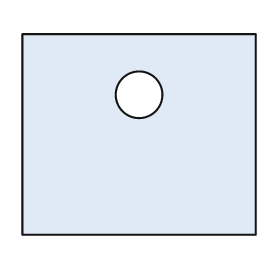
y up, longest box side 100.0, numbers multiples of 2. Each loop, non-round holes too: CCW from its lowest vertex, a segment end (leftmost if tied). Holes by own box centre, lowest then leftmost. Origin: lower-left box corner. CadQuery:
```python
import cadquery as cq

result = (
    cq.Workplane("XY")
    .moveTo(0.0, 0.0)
    .lineTo(100.0, 0.0)
    .lineTo(100.0, 86.0)
    .lineTo(0.0, 86.0)
    .close()
    .moveTo(50.0, 60.0)
    .circle(10.0)
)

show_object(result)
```